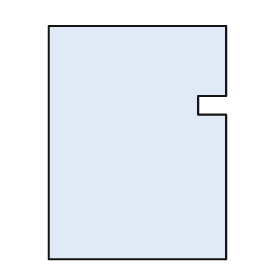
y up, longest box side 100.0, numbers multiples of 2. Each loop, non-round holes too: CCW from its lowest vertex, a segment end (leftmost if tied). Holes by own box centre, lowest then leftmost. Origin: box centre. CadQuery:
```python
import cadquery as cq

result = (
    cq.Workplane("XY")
    .moveTo(-38.0, -50.0)
    .lineTo(38.0, -50.0)
    .lineTo(38.0, 12.0)
    .lineTo(26.0, 12.0)
    .lineTo(26.0, 20.0)
    .lineTo(38.0, 20.0)
    .lineTo(38.0, 50.0)
    .lineTo(-38.0, 50.0)
    .close()
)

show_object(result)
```